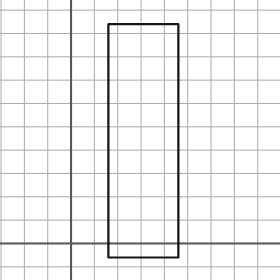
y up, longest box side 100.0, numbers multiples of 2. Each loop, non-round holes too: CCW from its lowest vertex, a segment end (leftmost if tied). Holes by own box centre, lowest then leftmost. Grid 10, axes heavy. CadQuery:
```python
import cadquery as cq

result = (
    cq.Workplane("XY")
    .moveTo(16.0, -6.0)
    .lineTo(46.0, -6.0)
    .lineTo(46.0, 94.0)
    .lineTo(16.0, 94.0)
    .close()
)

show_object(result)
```